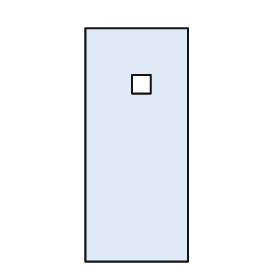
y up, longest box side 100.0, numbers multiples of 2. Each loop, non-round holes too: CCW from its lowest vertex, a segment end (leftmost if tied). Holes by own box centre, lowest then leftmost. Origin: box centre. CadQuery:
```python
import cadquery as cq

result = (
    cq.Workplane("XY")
    .moveTo(-22.0, -50.0)
    .lineTo(22.0, -50.0)
    .lineTo(22.0, 50.0)
    .lineTo(-22.0, 50.0)
    .close()
    .moveTo(-2.0, 22.0)
    .lineTo(6.0, 22.0)
    .lineTo(6.0, 30.0)
    .lineTo(-2.0, 30.0)
    .close()
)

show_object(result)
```